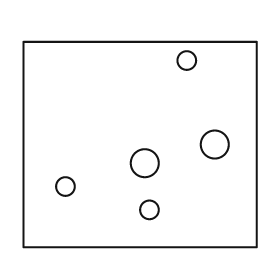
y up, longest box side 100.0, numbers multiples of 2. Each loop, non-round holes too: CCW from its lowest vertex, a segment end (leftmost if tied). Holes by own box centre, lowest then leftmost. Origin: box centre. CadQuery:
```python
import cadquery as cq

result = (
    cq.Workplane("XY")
    .moveTo(-50.0, -44.0)
    .lineTo(50.0, -44.0)
    .lineTo(50.0, 44.0)
    .lineTo(-50.0, 44.0)
    .close()
    .moveTo(4.0, -28.0)
    .circle(4.0)
    .moveTo(-32.0, -18.0)
    .circle(4.0)
    .moveTo(2.0, -8.0)
    .circle(6.0)
    .moveTo(32.0, 0.0)
    .circle(6.0)
    .moveTo(20.0, 36.0)
    .circle(4.0)
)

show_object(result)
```